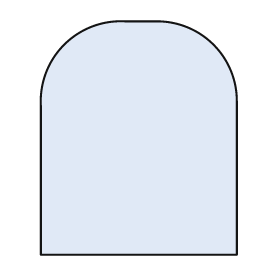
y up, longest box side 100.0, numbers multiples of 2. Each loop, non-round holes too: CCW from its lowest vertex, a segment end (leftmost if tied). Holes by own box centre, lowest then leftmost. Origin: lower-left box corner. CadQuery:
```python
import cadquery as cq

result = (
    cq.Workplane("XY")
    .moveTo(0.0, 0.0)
    .lineTo(84.0, 0.0)
    .lineTo(84.0, 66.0)
    .threePointArc((74.0, 90.0), (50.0, 100.0))
    .lineTo(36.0, 100.0)
    .threePointArc((10.0, 90.0), (0.0, 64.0))
    .close()
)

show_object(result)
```